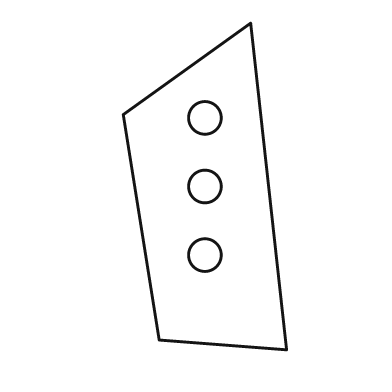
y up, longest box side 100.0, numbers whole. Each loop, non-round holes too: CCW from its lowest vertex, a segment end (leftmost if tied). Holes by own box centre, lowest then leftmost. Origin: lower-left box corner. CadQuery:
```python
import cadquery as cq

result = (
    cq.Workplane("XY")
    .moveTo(50.0, 0.0)
    .lineTo(39.0, 100.0)
    .lineTo(0.0, 72.0)
    .lineTo(11.0, 3.0)
    .close()
    .moveTo(25.0, 29.0)
    .circle(5.0)
    .moveTo(25.0, 50.0)
    .circle(5.0)
    .moveTo(25.0, 71.0)
    .circle(5.0)
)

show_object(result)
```